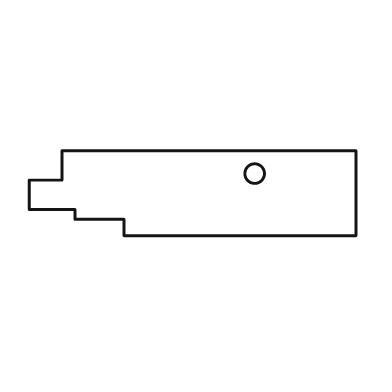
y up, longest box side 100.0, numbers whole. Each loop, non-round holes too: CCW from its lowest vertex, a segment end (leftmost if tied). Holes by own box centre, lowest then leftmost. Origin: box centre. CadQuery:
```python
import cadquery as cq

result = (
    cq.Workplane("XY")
    .moveTo(-21.0, -13.0)
    .lineTo(50.0, -13.0)
    .lineTo(50.0, 13.0)
    .lineTo(-40.0, 13.0)
    .lineTo(-40.0, 4.0)
    .lineTo(-50.0, 4.0)
    .lineTo(-50.0, -5.0)
    .lineTo(-36.0, -5.0)
    .lineTo(-36.0, -8.0)
    .lineTo(-21.0, -8.0)
    .close()
    .moveTo(19.0, 6.0)
    .circle(3.0)
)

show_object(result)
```